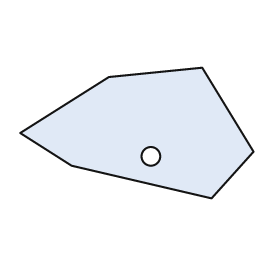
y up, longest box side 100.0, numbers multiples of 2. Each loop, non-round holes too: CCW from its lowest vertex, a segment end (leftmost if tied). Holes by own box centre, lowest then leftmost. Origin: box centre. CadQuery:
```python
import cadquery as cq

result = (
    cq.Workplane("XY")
    .moveTo(32.0, -28.0)
    .lineTo(50.0, -8.0)
    .lineTo(28.0, 28.0)
    .lineTo(-12.0, 24.0)
    .lineTo(-50.0, 0.0)
    .lineTo(-28.0, -14.0)
    .close()
    .moveTo(6.0, -10.0)
    .circle(4.0)
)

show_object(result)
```